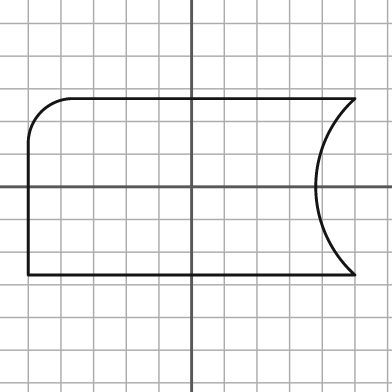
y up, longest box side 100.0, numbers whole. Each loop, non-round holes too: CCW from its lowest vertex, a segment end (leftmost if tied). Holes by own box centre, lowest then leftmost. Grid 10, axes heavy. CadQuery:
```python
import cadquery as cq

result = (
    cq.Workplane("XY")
    .moveTo(-50.0, -27.0)
    .lineTo(50.0, -27.0)
    .threePointArc((38.0, 0.0), (50.0, 27.0))
    .lineTo(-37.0, 27.0)
    .threePointArc((-46.0, 23.0), (-50.0, 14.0))
    .close()
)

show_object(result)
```